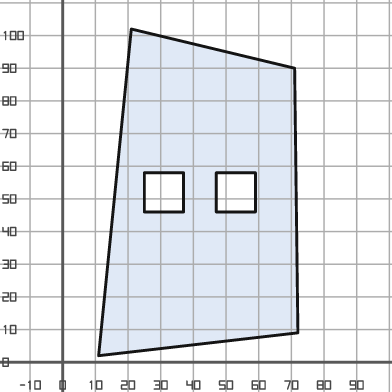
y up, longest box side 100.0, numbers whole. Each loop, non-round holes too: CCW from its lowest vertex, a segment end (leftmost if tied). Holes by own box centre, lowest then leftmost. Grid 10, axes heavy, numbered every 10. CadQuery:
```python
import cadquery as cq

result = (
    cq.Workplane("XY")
    .moveTo(11.0, 2.0)
    .lineTo(72.0, 9.0)
    .lineTo(71.0, 90.0)
    .lineTo(21.0, 102.0)
    .close()
    .moveTo(25.0, 46.0)
    .lineTo(37.0, 46.0)
    .lineTo(37.0, 58.0)
    .lineTo(25.0, 58.0)
    .close()
    .moveTo(47.0, 46.0)
    .lineTo(59.0, 46.0)
    .lineTo(59.0, 58.0)
    .lineTo(47.0, 58.0)
    .close()
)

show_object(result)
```